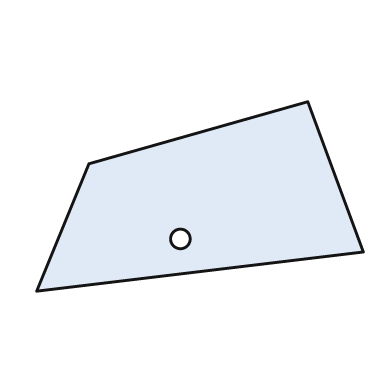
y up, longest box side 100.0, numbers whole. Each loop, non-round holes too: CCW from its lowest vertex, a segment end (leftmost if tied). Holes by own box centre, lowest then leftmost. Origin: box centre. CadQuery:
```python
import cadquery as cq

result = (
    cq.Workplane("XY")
    .moveTo(-50.0, -29.0)
    .lineTo(50.0, -17.0)
    .lineTo(33.0, 29.0)
    .lineTo(-34.0, 10.0)
    .close()
    .moveTo(-6.0, -13.0)
    .circle(3.0)
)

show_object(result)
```